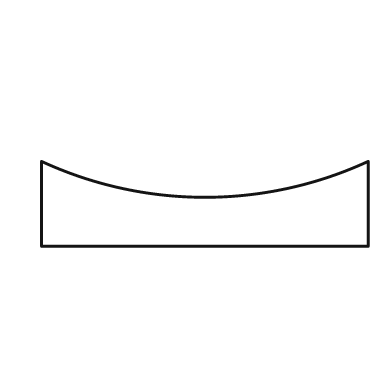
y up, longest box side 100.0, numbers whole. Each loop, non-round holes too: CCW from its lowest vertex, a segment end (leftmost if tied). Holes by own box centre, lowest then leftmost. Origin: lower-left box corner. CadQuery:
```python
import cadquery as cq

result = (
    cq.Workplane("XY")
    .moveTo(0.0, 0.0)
    .lineTo(100.0, 0.0)
    .lineTo(100.0, 26.0)
    .threePointArc((50.0, 15.0), (0.0, 26.0))
    .close()
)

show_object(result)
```